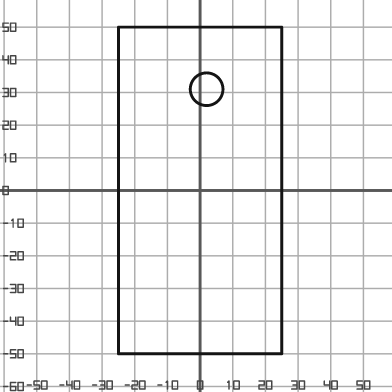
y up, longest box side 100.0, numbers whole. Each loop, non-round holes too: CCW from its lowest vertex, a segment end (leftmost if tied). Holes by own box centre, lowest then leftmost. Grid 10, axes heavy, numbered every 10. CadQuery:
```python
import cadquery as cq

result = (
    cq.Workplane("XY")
    .moveTo(-25.0, -50.0)
    .lineTo(25.0, -50.0)
    .lineTo(25.0, 50.0)
    .lineTo(-25.0, 50.0)
    .close()
    .moveTo(2.0, 31.0)
    .circle(5.0)
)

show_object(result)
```